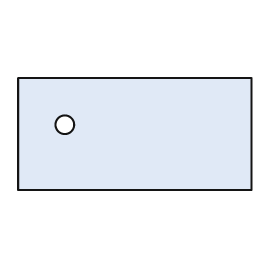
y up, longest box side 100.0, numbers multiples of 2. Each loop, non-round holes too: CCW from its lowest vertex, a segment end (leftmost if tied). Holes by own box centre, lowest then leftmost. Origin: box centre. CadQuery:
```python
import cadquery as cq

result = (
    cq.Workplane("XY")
    .moveTo(-50.0, -24.0)
    .lineTo(50.0, -24.0)
    .lineTo(50.0, 24.0)
    .lineTo(-50.0, 24.0)
    .close()
    .moveTo(-30.0, 4.0)
    .circle(4.0)
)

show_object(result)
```